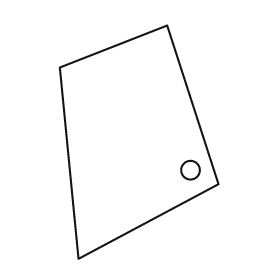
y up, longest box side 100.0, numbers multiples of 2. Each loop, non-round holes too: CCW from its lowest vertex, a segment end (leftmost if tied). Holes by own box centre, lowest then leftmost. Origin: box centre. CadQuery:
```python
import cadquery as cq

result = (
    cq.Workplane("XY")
    .moveTo(-26.0, -50.0)
    .lineTo(34.0, -18.0)
    .lineTo(12.0, 50.0)
    .lineTo(-34.0, 32.0)
    .close()
    .moveTo(22.0, -12.0)
    .circle(4.0)
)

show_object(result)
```